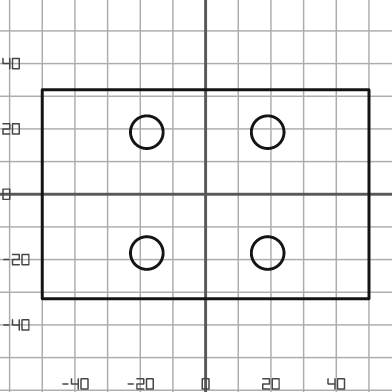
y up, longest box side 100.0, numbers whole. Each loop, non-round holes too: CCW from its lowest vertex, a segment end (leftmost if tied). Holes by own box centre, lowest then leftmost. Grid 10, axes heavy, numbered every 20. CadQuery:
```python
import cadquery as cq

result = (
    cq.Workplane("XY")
    .moveTo(-50.0, -32.0)
    .lineTo(50.0, -32.0)
    .lineTo(50.0, 32.0)
    .lineTo(-50.0, 32.0)
    .close()
    .moveTo(-18.0, -18.0)
    .circle(5.0)
    .moveTo(19.0, -18.0)
    .circle(5.0)
    .moveTo(-18.0, 19.0)
    .circle(5.0)
    .moveTo(19.0, 19.0)
    .circle(5.0)
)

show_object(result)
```